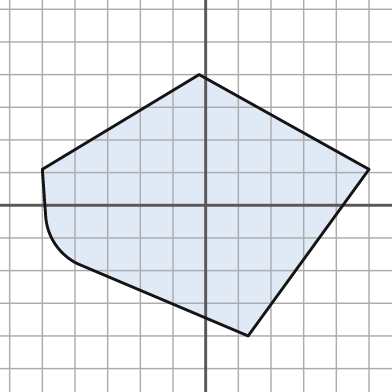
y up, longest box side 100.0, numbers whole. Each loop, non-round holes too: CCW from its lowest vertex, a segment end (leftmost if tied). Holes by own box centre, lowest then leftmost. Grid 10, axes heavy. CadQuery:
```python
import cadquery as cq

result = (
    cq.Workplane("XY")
    .moveTo(13.0, -40.0)
    .lineTo(50.0, 11.0)
    .lineTo(-2.0, 40.0)
    .lineTo(-50.0, 11.0)
    .lineTo(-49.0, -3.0)
    .threePointArc((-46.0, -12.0), (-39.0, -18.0))
    .close()
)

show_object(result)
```